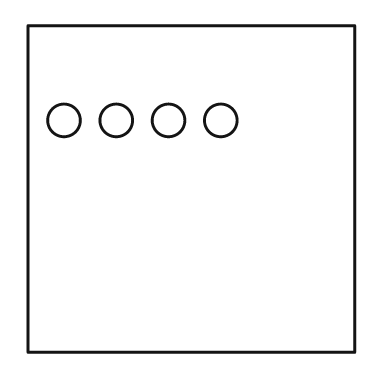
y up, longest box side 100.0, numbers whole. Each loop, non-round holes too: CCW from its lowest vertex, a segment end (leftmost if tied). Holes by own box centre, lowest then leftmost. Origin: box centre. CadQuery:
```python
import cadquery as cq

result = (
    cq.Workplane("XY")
    .moveTo(-50.0, -50.0)
    .lineTo(50.0, -50.0)
    .lineTo(50.0, 50.0)
    .lineTo(-50.0, 50.0)
    .close()
    .moveTo(-39.0, 21.0)
    .circle(5.0)
    .moveTo(-23.0, 21.0)
    .circle(5.0)
    .moveTo(-7.0, 21.0)
    .circle(5.0)
    .moveTo(9.0, 21.0)
    .circle(5.0)
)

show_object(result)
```